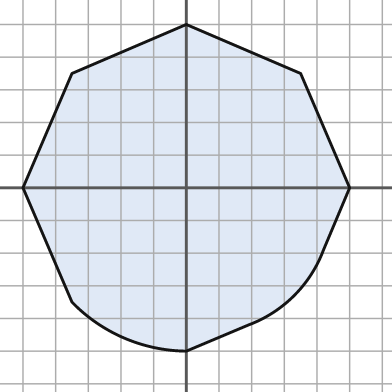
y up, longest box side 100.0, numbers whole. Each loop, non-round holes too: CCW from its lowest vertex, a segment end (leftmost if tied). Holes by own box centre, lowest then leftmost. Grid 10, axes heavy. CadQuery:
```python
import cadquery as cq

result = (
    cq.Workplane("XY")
    .moveTo(0.0, -50.0)
    .lineTo(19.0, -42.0)
    .threePointArc((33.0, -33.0), (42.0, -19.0))
    .lineTo(50.0, 0.0)
    .lineTo(35.0, 35.0)
    .lineTo(0.0, 50.0)
    .lineTo(-35.0, 35.0)
    .lineTo(-50.0, 0.0)
    .lineTo(-35.0, -35.0)
    .threePointArc((-19.0, -46.0), (0.0, -50.0))
    .close()
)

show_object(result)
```